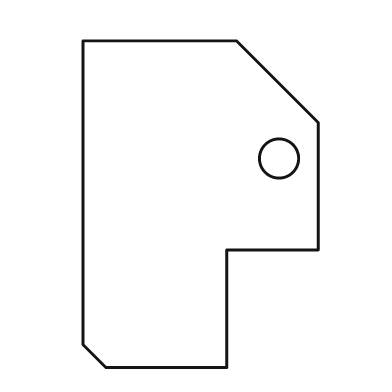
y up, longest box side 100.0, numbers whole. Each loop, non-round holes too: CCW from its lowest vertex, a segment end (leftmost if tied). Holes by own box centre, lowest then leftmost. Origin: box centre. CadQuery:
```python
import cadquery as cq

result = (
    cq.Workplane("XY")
    .moveTo(-29.0, -50.0)
    .lineTo(8.0, -50.0)
    .lineTo(8.0, -14.0)
    .lineTo(36.0, -14.0)
    .lineTo(36.0, 25.0)
    .lineTo(11.0, 50.0)
    .lineTo(-36.0, 50.0)
    .lineTo(-36.0, -43.0)
    .close()
    .moveTo(24.0, 14.0)
    .circle(6.0)
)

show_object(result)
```